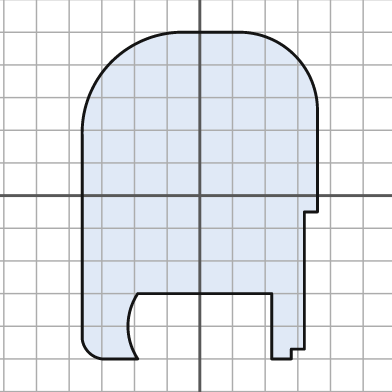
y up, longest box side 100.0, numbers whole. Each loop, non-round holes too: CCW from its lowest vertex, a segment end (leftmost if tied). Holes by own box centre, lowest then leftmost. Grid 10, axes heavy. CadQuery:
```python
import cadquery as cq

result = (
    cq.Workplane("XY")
    .moveTo(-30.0, -50.0)
    .lineTo(-19.0, -50.0)
    .threePointArc((-22.0, -40.0), (-19.0, -30.0))
    .lineTo(22.0, -30.0)
    .lineTo(22.0, -50.0)
    .lineTo(28.0, -50.0)
    .lineTo(28.0, -47.0)
    .lineTo(32.0, -47.0)
    .lineTo(32.0, -5.0)
    .lineTo(36.0, -5.0)
    .lineTo(36.0, 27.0)
    .threePointArc((29.0, 43.0), (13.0, 50.0))
    .lineTo(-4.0, 50.0)
    .threePointArc((-27.0, 41.0), (-36.0, 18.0))
    .lineTo(-36.0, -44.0)
    .threePointArc((-34.0, -48.0), (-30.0, -50.0))
    .close()
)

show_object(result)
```